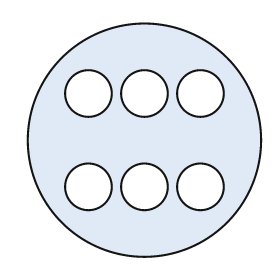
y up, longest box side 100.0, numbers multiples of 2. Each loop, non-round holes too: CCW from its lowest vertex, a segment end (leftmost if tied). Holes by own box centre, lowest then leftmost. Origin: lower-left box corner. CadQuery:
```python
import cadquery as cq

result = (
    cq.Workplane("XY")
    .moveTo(50.0, 50.0)
    .circle(50.0)
    .moveTo(26.0, 30.0)
    .circle(10.0)
    .moveTo(50.0, 30.0)
    .circle(10.0)
    .moveTo(74.0, 30.0)
    .circle(10.0)
    .moveTo(26.0, 70.0)
    .circle(10.0)
    .moveTo(50.0, 70.0)
    .circle(10.0)
    .moveTo(74.0, 70.0)
    .circle(10.0)
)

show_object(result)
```